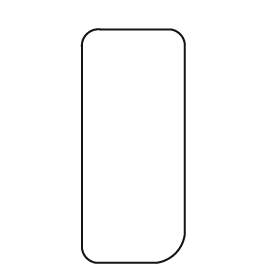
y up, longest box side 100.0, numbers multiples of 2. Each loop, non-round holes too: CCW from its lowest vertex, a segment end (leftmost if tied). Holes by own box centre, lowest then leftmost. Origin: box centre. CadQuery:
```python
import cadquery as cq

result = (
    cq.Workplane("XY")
    .moveTo(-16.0, -50.0)
    .lineTo(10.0, -50.0)
    .threePointArc((18.0, -46.0), (22.0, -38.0))
    .lineTo(22.0, 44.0)
    .threePointArc((20.0, 48.0), (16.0, 50.0))
    .lineTo(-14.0, 50.0)
    .threePointArc((-20.0, 48.0), (-22.0, 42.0))
    .lineTo(-22.0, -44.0)
    .threePointArc((-20.0, -48.0), (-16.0, -50.0))
    .close()
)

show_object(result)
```